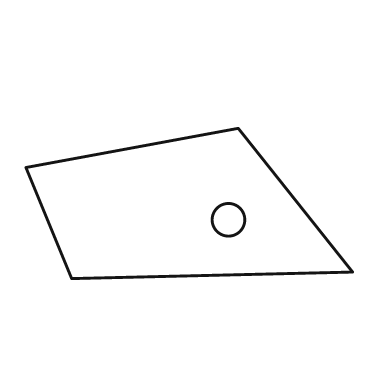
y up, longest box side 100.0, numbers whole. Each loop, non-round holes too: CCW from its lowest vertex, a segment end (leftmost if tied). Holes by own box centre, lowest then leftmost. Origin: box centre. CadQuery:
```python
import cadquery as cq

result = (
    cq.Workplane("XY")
    .moveTo(-36.0, -23.0)
    .lineTo(50.0, -21.0)
    .lineTo(15.0, 23.0)
    .lineTo(-50.0, 11.0)
    .close()
    .moveTo(12.0, -5.0)
    .circle(5.0)
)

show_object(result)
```